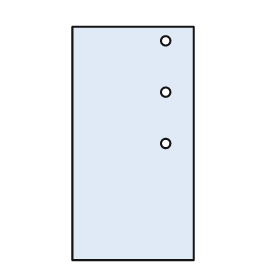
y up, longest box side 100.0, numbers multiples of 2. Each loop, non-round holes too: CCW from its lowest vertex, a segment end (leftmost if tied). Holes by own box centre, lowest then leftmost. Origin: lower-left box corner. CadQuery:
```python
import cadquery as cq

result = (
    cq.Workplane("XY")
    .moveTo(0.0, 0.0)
    .lineTo(52.0, 0.0)
    .lineTo(52.0, 100.0)
    .lineTo(0.0, 100.0)
    .close()
    .moveTo(40.0, 50.0)
    .circle(2.0)
    .moveTo(40.0, 72.0)
    .circle(2.0)
    .moveTo(40.0, 94.0)
    .circle(2.0)
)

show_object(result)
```